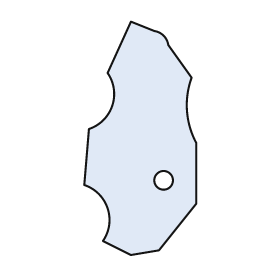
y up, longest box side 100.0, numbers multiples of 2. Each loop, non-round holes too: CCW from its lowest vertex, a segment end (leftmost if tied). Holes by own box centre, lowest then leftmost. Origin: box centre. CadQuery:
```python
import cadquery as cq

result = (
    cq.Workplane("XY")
    .moveTo(-4.0, -50.0)
    .lineTo(8.0, -48.0)
    .lineTo(24.0, -28.0)
    .lineTo(24.0, -2.0)
    .threePointArc((20.0, 12.0), (22.0, 26.0))
    .lineTo(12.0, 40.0)
    .threePointArc((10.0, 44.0), (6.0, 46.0))
    .lineTo(-4.0, 50.0)
    .lineTo(-14.0, 28.0)
    .threePointArc((-12.0, 14.0), (-22.0, 4.0))
    .lineTo(-24.0, -20.0)
    .threePointArc((-14.0, -30.0), (-16.0, -44.0))
    .close()
    .moveTo(10.0, -18.0)
    .circle(4.0)
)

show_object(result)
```